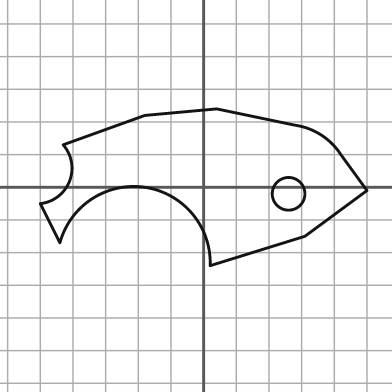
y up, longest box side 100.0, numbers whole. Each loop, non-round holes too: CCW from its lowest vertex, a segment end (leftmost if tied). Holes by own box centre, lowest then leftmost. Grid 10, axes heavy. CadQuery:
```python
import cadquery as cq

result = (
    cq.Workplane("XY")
    .moveTo(2.0, -24.0)
    .lineTo(31.0, -15.0)
    .lineTo(50.0, -1.0)
    .lineTo(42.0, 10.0)
    .threePointArc((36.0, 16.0), (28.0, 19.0))
    .lineTo(4.0, 24.0)
    .lineTo(-18.0, 22.0)
    .lineTo(-43.0, 13.0)
    .threePointArc((-41.0, 2.0), (-50.0, -5.0))
    .lineTo(-44.0, -17.0)
    .threePointArc((-18.0, 0.0), (2.0, -24.0))
    .close()
    .moveTo(26.0, -2.0)
    .circle(5.0)
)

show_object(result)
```